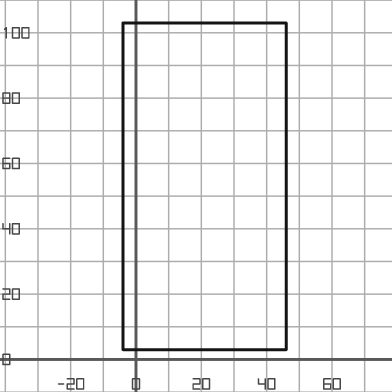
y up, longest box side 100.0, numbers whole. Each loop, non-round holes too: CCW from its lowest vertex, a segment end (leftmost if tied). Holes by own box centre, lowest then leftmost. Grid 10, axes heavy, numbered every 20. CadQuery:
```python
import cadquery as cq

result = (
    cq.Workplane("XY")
    .moveTo(-4.0, 3.0)
    .lineTo(46.0, 3.0)
    .lineTo(46.0, 103.0)
    .lineTo(-4.0, 103.0)
    .close()
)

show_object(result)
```